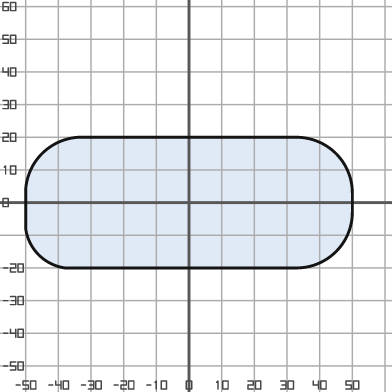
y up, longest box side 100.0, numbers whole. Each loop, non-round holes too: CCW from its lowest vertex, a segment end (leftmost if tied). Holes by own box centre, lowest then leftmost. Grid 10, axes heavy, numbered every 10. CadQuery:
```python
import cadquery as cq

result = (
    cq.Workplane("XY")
    .moveTo(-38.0, -20.0)
    .lineTo(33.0, -20.0)
    .threePointArc((45.0, -15.0), (50.0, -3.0))
    .lineTo(50.0, 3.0)
    .threePointArc((45.0, 15.0), (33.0, 20.0))
    .lineTo(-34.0, 20.0)
    .threePointArc((-45.0, 15.0), (-50.0, 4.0))
    .lineTo(-50.0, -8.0)
    .threePointArc((-46.0, -16.0), (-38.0, -20.0))
    .close()
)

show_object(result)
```